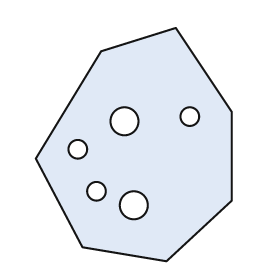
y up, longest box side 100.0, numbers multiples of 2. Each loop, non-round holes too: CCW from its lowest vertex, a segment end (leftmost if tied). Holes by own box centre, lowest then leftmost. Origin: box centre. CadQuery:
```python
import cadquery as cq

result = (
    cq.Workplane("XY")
    .moveTo(14.0, -50.0)
    .lineTo(42.0, -24.0)
    .lineTo(42.0, 14.0)
    .lineTo(18.0, 50.0)
    .lineTo(-14.0, 40.0)
    .lineTo(-42.0, -6.0)
    .lineTo(-22.0, -44.0)
    .close()
    .moveTo(0.0, -26.0)
    .circle(6.0)
    .moveTo(-16.0, -20.0)
    .circle(4.0)
    .moveTo(-24.0, -2.0)
    .circle(4.0)
    .moveTo(-4.0, 10.0)
    .circle(6.0)
    .moveTo(24.0, 12.0)
    .circle(4.0)
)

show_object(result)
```